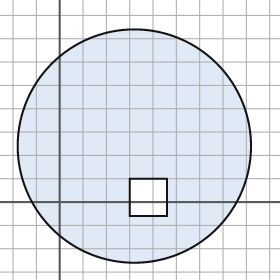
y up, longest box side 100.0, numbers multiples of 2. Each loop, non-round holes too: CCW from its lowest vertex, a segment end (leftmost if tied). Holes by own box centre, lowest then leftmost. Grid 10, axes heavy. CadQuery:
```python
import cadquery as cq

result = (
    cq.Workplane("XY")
    .moveTo(32.0, 24.0)
    .circle(50.0)
    .moveTo(30.0, -6.0)
    .lineTo(46.0, -6.0)
    .lineTo(46.0, 10.0)
    .lineTo(30.0, 10.0)
    .close()
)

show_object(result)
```